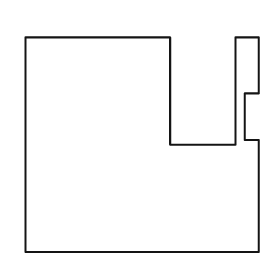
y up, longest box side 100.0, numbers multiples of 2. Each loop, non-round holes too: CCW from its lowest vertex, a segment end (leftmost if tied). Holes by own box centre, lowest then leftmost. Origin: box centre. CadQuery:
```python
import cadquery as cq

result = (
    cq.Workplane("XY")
    .moveTo(-50.0, -46.0)
    .lineTo(50.0, -46.0)
    .lineTo(50.0, 2.0)
    .lineTo(44.0, 2.0)
    .lineTo(44.0, 22.0)
    .lineTo(50.0, 22.0)
    .lineTo(50.0, 46.0)
    .lineTo(40.0, 46.0)
    .lineTo(40.0, 0.0)
    .lineTo(12.0, 0.0)
    .lineTo(12.0, 46.0)
    .lineTo(-50.0, 46.0)
    .close()
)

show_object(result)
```